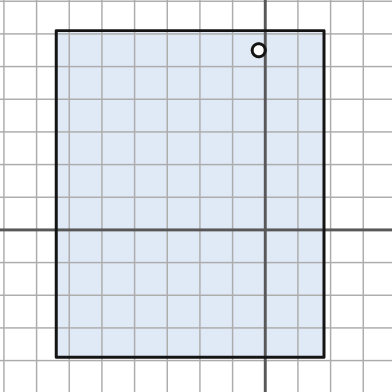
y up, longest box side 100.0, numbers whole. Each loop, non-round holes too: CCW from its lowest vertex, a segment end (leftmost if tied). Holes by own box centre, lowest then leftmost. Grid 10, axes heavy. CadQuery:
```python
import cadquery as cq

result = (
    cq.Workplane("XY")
    .moveTo(-64.0, -39.0)
    .lineTo(18.0, -39.0)
    .lineTo(18.0, 61.0)
    .lineTo(-64.0, 61.0)
    .close()
    .moveTo(-2.0, 55.0)
    .circle(2.0)
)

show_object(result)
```